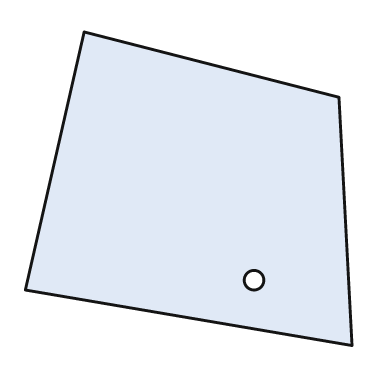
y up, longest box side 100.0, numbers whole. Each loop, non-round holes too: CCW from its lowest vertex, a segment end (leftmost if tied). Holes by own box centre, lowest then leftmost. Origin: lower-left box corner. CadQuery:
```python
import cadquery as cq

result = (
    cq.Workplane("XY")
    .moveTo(100.0, 0.0)
    .lineTo(96.0, 76.0)
    .lineTo(18.0, 96.0)
    .lineTo(0.0, 17.0)
    .close()
    .moveTo(70.0, 20.0)
    .circle(3.0)
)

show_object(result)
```